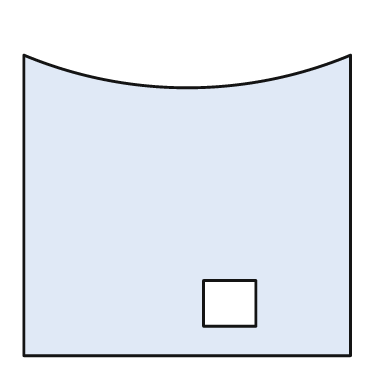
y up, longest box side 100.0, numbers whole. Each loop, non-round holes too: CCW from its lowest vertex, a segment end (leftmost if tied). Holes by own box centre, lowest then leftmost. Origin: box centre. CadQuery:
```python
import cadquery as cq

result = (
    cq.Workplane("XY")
    .moveTo(-50.0, -46.0)
    .lineTo(50.0, -46.0)
    .lineTo(50.0, 46.0)
    .threePointArc((0.0, 36.0), (-50.0, 46.0))
    .close()
    .moveTo(5.0, -37.0)
    .lineTo(21.0, -37.0)
    .lineTo(21.0, -23.0)
    .lineTo(5.0, -23.0)
    .close()
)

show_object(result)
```